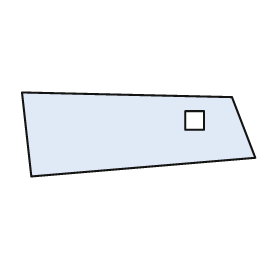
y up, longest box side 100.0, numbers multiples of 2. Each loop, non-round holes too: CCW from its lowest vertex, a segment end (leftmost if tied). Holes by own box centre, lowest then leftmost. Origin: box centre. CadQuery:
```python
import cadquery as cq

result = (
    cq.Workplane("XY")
    .moveTo(-46.0, -18.0)
    .lineTo(50.0, -10.0)
    .lineTo(40.0, 16.0)
    .lineTo(-50.0, 18.0)
    .close()
    .moveTo(20.0, 2.0)
    .lineTo(28.0, 2.0)
    .lineTo(28.0, 10.0)
    .lineTo(20.0, 10.0)
    .close()
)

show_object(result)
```